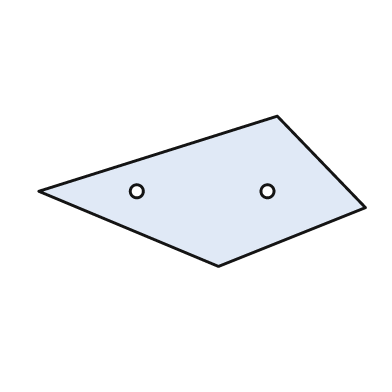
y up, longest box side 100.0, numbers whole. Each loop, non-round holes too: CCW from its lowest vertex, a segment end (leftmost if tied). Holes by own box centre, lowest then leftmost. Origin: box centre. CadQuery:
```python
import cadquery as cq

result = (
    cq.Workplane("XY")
    .moveTo(5.0, -23.0)
    .lineTo(50.0, -5.0)
    .lineTo(23.0, 23.0)
    .lineTo(-50.0, 0.0)
    .close()
    .moveTo(-20.0, 0.0)
    .circle(2.0)
    .moveTo(20.0, 0.0)
    .circle(2.0)
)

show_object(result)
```